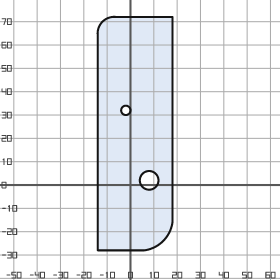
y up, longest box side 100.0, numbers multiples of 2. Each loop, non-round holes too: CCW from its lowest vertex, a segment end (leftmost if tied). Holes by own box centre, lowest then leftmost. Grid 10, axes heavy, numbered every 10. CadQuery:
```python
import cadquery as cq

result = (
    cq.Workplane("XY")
    .moveTo(-14.0, -28.0)
    .lineTo(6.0, -28.0)
    .threePointArc((14.0, -24.0), (18.0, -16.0))
    .lineTo(18.0, 72.0)
    .lineTo(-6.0, 72.0)
    .threePointArc((-12.0, 70.0), (-14.0, 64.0))
    .close()
    .moveTo(8.0, 2.0)
    .circle(4.0)
    .moveTo(-2.0, 32.0)
    .circle(2.0)
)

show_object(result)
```